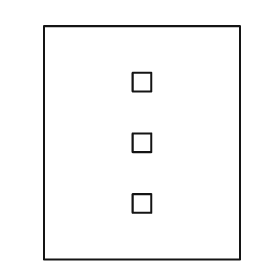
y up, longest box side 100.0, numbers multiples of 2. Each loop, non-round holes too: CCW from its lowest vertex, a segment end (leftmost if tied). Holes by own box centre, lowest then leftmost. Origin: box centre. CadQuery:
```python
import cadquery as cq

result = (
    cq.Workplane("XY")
    .moveTo(-42.0, -50.0)
    .lineTo(42.0, -50.0)
    .lineTo(42.0, 50.0)
    .lineTo(-42.0, 50.0)
    .close()
    .moveTo(-4.0, -30.0)
    .lineTo(4.0, -30.0)
    .lineTo(4.0, -22.0)
    .lineTo(-4.0, -22.0)
    .close()
    .moveTo(-4.0, -4.0)
    .lineTo(4.0, -4.0)
    .lineTo(4.0, 4.0)
    .lineTo(-4.0, 4.0)
    .close()
    .moveTo(-4.0, 22.0)
    .lineTo(4.0, 22.0)
    .lineTo(4.0, 30.0)
    .lineTo(-4.0, 30.0)
    .close()
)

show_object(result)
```